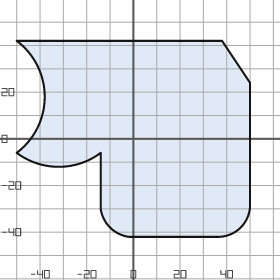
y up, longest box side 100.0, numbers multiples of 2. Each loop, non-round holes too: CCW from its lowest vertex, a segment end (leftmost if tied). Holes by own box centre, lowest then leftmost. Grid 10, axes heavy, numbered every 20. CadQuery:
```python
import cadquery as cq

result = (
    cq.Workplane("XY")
    .moveTo(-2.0, -42.0)
    .lineTo(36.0, -42.0)
    .threePointArc((46.0, -38.0), (50.0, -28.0))
    .lineTo(50.0, 24.0)
    .lineTo(38.0, 42.0)
    .lineTo(-50.0, 42.0)
    .threePointArc((-38.0, 18.0), (-50.0, -6.0))
    .threePointArc((-32.0, -12.0), (-14.0, -6.0))
    .lineTo(-14.0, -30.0)
    .threePointArc((-10.0, -38.0), (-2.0, -42.0))
    .close()
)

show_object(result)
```